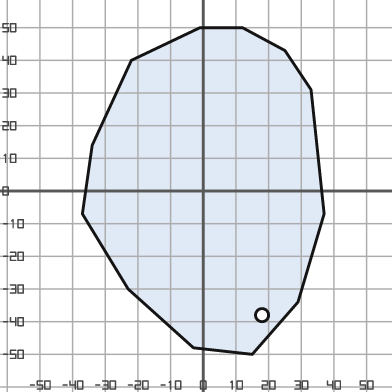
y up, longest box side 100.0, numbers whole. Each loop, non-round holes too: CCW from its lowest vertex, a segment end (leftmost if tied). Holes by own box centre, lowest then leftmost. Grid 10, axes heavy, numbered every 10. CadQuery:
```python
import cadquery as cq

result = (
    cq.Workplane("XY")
    .moveTo(15.0, -50.0)
    .lineTo(29.0, -34.0)
    .lineTo(37.0, -7.0)
    .lineTo(33.0, 31.0)
    .lineTo(25.0, 43.0)
    .lineTo(12.0, 50.0)
    .lineTo(-1.0, 50.0)
    .lineTo(-22.0, 40.0)
    .lineTo(-34.0, 14.0)
    .lineTo(-37.0, -7.0)
    .lineTo(-23.0, -30.0)
    .lineTo(-3.0, -48.0)
    .close()
    .moveTo(18.0, -38.0)
    .circle(2.0)
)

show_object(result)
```